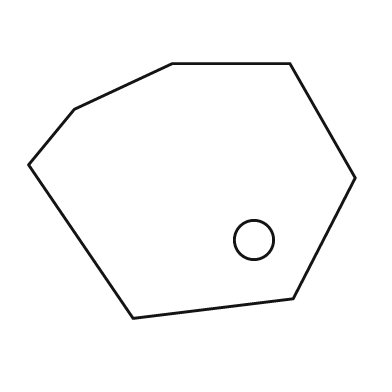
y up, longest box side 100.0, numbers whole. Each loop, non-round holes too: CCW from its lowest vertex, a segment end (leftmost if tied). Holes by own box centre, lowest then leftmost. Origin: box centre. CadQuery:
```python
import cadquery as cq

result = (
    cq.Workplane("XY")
    .moveTo(-18.0, -39.0)
    .lineTo(31.0, -33.0)
    .lineTo(50.0, 4.0)
    .lineTo(30.0, 39.0)
    .lineTo(-6.0, 39.0)
    .lineTo(-36.0, 25.0)
    .lineTo(-50.0, 8.0)
    .close()
    .moveTo(19.0, -15.0)
    .circle(6.0)
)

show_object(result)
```